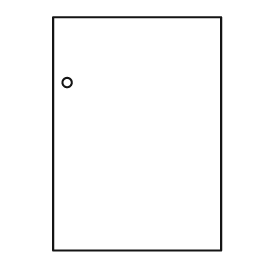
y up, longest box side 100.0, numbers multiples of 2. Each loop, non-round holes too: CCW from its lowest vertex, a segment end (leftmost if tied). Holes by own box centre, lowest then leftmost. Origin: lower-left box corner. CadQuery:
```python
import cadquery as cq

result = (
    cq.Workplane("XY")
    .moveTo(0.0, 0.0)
    .lineTo(72.0, 0.0)
    .lineTo(72.0, 100.0)
    .lineTo(0.0, 100.0)
    .close()
    .moveTo(6.0, 72.0)
    .circle(2.0)
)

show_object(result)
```